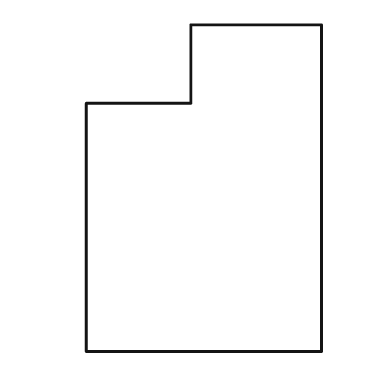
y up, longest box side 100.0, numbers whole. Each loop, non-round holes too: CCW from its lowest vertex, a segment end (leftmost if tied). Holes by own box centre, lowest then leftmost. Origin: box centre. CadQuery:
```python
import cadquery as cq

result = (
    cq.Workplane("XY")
    .moveTo(-36.0, -50.0)
    .lineTo(36.0, -50.0)
    .lineTo(36.0, 50.0)
    .lineTo(-4.0, 50.0)
    .lineTo(-4.0, 26.0)
    .lineTo(-36.0, 26.0)
    .close()
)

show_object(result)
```